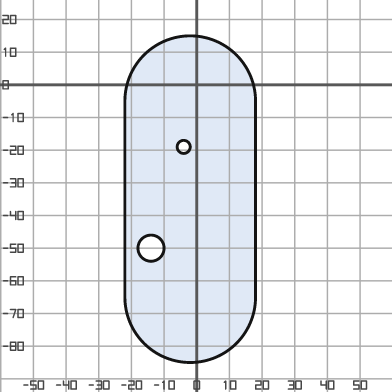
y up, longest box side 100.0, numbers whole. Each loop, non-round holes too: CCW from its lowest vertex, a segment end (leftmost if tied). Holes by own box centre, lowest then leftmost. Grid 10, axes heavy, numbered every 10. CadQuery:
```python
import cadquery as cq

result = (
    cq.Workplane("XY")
    .moveTo(-22.0, -65.0)
    .threePointArc((-2.0, -85.0), (18.0, -65.0))
    .lineTo(18.0, -5.0)
    .threePointArc((-2.0, 15.0), (-22.0, -5.0))
    .close()
    .moveTo(-14.0, -50.0)
    .circle(4.0)
    .moveTo(-4.0, -19.0)
    .circle(2.0)
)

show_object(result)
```